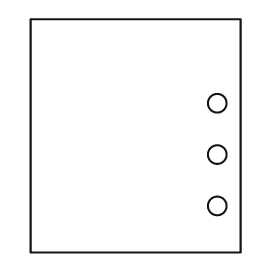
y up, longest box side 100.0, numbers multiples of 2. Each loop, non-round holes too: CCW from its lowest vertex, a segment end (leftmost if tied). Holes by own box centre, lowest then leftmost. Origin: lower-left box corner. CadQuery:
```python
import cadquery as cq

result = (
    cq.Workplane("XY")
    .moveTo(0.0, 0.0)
    .lineTo(90.0, 0.0)
    .lineTo(90.0, 100.0)
    .lineTo(0.0, 100.0)
    .close()
    .moveTo(80.0, 20.0)
    .circle(4.0)
    .moveTo(80.0, 42.0)
    .circle(4.0)
    .moveTo(80.0, 64.0)
    .circle(4.0)
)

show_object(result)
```